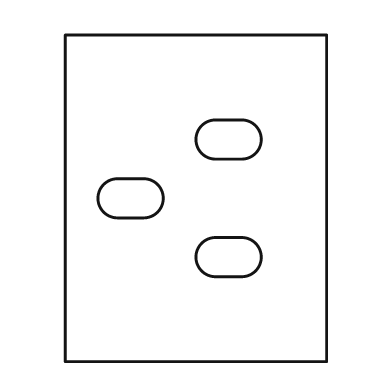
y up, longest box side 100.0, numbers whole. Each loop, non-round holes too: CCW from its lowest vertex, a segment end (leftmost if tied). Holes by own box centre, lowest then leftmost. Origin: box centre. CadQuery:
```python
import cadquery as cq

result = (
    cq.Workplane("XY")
    .moveTo(-40.0, -50.0)
    .lineTo(40.0, -50.0)
    .lineTo(40.0, 50.0)
    .lineTo(-40.0, 50.0)
    .close()
    .moveTo(6.0, -24.0)
    .lineTo(14.0, -24.0)
    .threePointArc((20.0, -18.0), (14.0, -12.0))
    .lineTo(6.0, -12.0)
    .threePointArc((0.0, -18.0), (6.0, -24.0))
    .close()
    .moveTo(-24.0, -6.0)
    .lineTo(-16.0, -6.0)
    .threePointArc((-10.0, 0.0), (-16.0, 6.0))
    .lineTo(-24.0, 6.0)
    .threePointArc((-30.0, 0.0), (-24.0, -6.0))
    .close()
    .moveTo(6.0, 12.0)
    .lineTo(14.0, 12.0)
    .threePointArc((20.0, 18.0), (14.0, 24.0))
    .lineTo(6.0, 24.0)
    .threePointArc((0.0, 18.0), (6.0, 12.0))
    .close()
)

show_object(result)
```